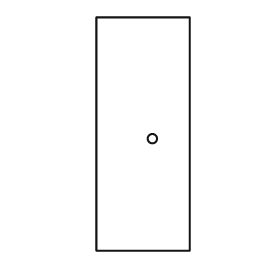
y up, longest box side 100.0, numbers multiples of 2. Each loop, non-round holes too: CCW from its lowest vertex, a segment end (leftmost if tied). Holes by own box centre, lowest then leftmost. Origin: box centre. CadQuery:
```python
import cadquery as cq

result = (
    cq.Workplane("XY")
    .moveTo(-20.0, -50.0)
    .lineTo(20.0, -50.0)
    .lineTo(20.0, 50.0)
    .lineTo(-20.0, 50.0)
    .close()
    .moveTo(4.0, -2.0)
    .circle(2.0)
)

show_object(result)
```